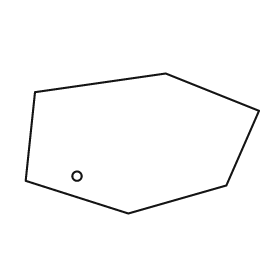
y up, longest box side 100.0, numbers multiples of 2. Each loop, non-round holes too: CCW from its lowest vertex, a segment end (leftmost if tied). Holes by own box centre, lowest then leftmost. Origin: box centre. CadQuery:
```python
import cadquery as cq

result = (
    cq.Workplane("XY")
    .moveTo(-6.0, -30.0)
    .lineTo(36.0, -18.0)
    .lineTo(50.0, 14.0)
    .lineTo(10.0, 30.0)
    .lineTo(-46.0, 22.0)
    .lineTo(-50.0, -16.0)
    .close()
    .moveTo(-28.0, -14.0)
    .circle(2.0)
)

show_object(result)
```